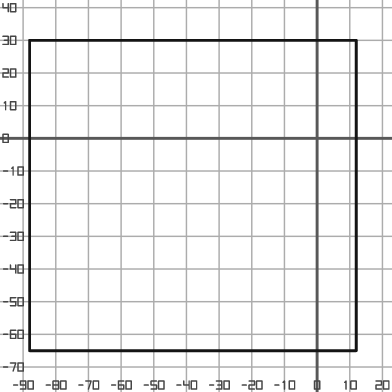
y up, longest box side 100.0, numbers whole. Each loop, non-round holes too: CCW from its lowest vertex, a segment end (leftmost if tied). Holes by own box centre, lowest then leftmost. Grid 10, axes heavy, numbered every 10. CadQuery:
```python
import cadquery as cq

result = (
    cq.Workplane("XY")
    .moveTo(-88.0, -65.0)
    .lineTo(12.0, -65.0)
    .lineTo(12.0, 30.0)
    .lineTo(-88.0, 30.0)
    .close()
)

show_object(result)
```